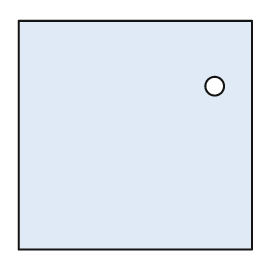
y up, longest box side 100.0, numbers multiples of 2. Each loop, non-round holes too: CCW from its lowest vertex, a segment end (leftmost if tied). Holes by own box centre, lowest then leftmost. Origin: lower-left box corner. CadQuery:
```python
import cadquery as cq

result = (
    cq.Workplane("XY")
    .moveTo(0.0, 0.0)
    .lineTo(100.0, 0.0)
    .lineTo(100.0, 98.0)
    .lineTo(0.0, 98.0)
    .close()
    .moveTo(84.0, 70.0)
    .circle(4.0)
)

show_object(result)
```